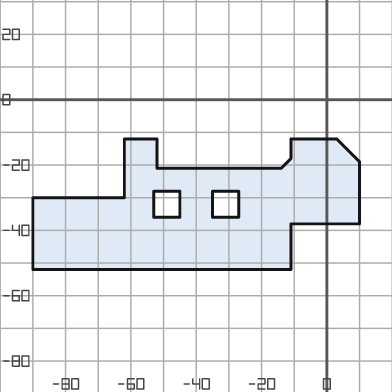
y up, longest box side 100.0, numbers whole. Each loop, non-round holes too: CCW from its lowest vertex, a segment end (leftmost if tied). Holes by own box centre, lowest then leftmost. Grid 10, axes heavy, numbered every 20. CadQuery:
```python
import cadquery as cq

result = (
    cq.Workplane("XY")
    .moveTo(-90.0, -52.0)
    .lineTo(-11.0, -52.0)
    .lineTo(-11.0, -38.0)
    .lineTo(10.0, -38.0)
    .lineTo(10.0, -19.0)
    .lineTo(3.0, -12.0)
    .lineTo(-11.0, -12.0)
    .lineTo(-11.0, -18.0)
    .lineTo(-14.0, -21.0)
    .lineTo(-52.0, -21.0)
    .lineTo(-52.0, -12.0)
    .lineTo(-62.0, -12.0)
    .lineTo(-62.0, -30.0)
    .lineTo(-90.0, -30.0)
    .close()
    .moveTo(-53.0, -36.0)
    .lineTo(-45.0, -36.0)
    .lineTo(-45.0, -28.0)
    .lineTo(-53.0, -28.0)
    .close()
    .moveTo(-35.0, -36.0)
    .lineTo(-27.0, -36.0)
    .lineTo(-27.0, -28.0)
    .lineTo(-35.0, -28.0)
    .close()
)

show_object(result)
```